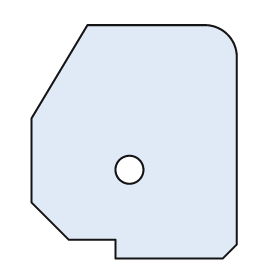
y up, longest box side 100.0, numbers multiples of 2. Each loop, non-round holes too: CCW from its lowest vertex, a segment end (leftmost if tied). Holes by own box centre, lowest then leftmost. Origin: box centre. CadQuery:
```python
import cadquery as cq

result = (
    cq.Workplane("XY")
    .moveTo(-8.0, -50.0)
    .lineTo(38.0, -50.0)
    .lineTo(44.0, -44.0)
    .lineTo(44.0, 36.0)
    .threePointArc((40.0, 46.0), (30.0, 50.0))
    .lineTo(-20.0, 50.0)
    .lineTo(-44.0, 10.0)
    .lineTo(-44.0, -26.0)
    .lineTo(-28.0, -42.0)
    .lineTo(-8.0, -42.0)
    .close()
    .moveTo(-2.0, -12.0)
    .circle(6.0)
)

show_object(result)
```